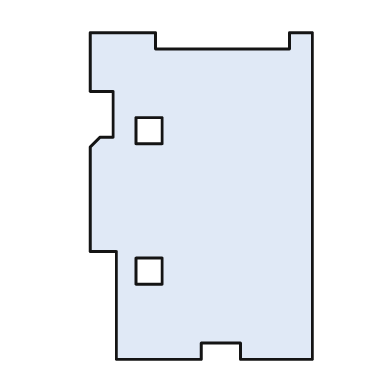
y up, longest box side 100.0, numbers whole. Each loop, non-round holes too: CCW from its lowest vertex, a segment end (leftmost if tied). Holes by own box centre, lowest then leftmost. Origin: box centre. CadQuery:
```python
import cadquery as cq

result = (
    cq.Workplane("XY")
    .moveTo(-26.0, -50.0)
    .lineTo(0.0, -50.0)
    .lineTo(0.0, -45.0)
    .lineTo(12.0, -45.0)
    .lineTo(12.0, -50.0)
    .lineTo(34.0, -50.0)
    .lineTo(34.0, 50.0)
    .lineTo(27.0, 50.0)
    .lineTo(27.0, 45.0)
    .lineTo(-14.0, 45.0)
    .lineTo(-14.0, 50.0)
    .lineTo(-34.0, 50.0)
    .lineTo(-34.0, 32.0)
    .lineTo(-27.0, 32.0)
    .lineTo(-27.0, 18.0)
    .lineTo(-31.0, 18.0)
    .lineTo(-34.0, 15.0)
    .lineTo(-34.0, -17.0)
    .lineTo(-26.0, -17.0)
    .close()
    .moveTo(-20.0, -27.0)
    .lineTo(-12.0, -27.0)
    .lineTo(-12.0, -19.0)
    .lineTo(-20.0, -19.0)
    .close()
    .moveTo(-20.0, 16.0)
    .lineTo(-12.0, 16.0)
    .lineTo(-12.0, 24.0)
    .lineTo(-20.0, 24.0)
    .close()
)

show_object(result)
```